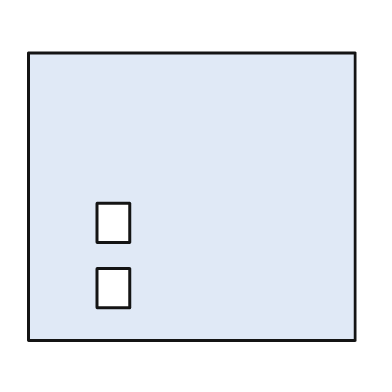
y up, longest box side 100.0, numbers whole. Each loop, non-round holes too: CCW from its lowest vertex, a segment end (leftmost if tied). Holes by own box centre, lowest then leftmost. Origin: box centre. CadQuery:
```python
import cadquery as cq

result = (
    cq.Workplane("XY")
    .moveTo(-50.0, -44.0)
    .lineTo(50.0, -44.0)
    .lineTo(50.0, 44.0)
    .lineTo(-50.0, 44.0)
    .close()
    .moveTo(-29.0, -34.0)
    .lineTo(-19.0, -34.0)
    .lineTo(-19.0, -22.0)
    .lineTo(-29.0, -22.0)
    .close()
    .moveTo(-29.0, -14.0)
    .lineTo(-19.0, -14.0)
    .lineTo(-19.0, -2.0)
    .lineTo(-29.0, -2.0)
    .close()
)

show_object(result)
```